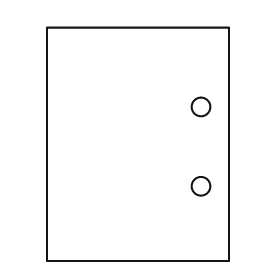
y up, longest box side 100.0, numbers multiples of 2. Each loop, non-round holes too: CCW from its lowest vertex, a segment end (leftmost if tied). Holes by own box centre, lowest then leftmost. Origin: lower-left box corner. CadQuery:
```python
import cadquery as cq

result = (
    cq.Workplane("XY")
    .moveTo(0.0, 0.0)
    .lineTo(78.0, 0.0)
    .lineTo(78.0, 100.0)
    .lineTo(0.0, 100.0)
    .close()
    .moveTo(66.0, 32.0)
    .circle(4.0)
    .moveTo(66.0, 66.0)
    .circle(4.0)
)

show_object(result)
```